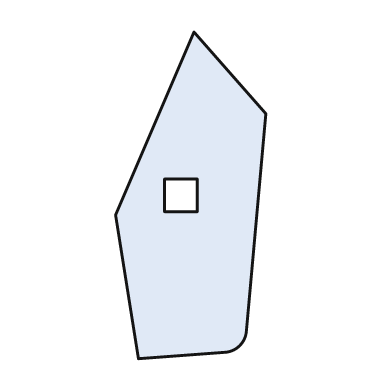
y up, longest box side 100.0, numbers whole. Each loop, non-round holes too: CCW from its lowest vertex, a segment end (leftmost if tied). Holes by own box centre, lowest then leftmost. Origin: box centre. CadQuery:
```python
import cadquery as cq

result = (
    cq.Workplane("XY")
    .moveTo(-16.0, -50.0)
    .lineTo(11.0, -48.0)
    .threePointArc((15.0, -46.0), (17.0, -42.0))
    .lineTo(23.0, 25.0)
    .lineTo(1.0, 50.0)
    .lineTo(-23.0, -6.0)
    .close()
    .moveTo(-8.0, -5.0)
    .lineTo(2.0, -5.0)
    .lineTo(2.0, 5.0)
    .lineTo(-8.0, 5.0)
    .close()
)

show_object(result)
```